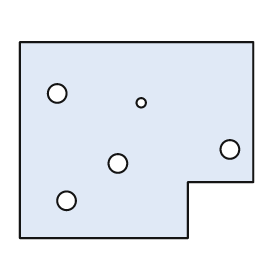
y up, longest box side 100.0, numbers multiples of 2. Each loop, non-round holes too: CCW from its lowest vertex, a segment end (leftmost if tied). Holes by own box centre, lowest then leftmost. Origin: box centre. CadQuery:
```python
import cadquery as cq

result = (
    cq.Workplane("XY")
    .moveTo(-50.0, -42.0)
    .lineTo(22.0, -42.0)
    .lineTo(22.0, -18.0)
    .lineTo(50.0, -18.0)
    .lineTo(50.0, 42.0)
    .lineTo(-50.0, 42.0)
    .close()
    .moveTo(-30.0, -26.0)
    .circle(4.0)
    .moveTo(-8.0, -10.0)
    .circle(4.0)
    .moveTo(40.0, -4.0)
    .circle(4.0)
    .moveTo(2.0, 16.0)
    .circle(2.0)
    .moveTo(-34.0, 20.0)
    .circle(4.0)
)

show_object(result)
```